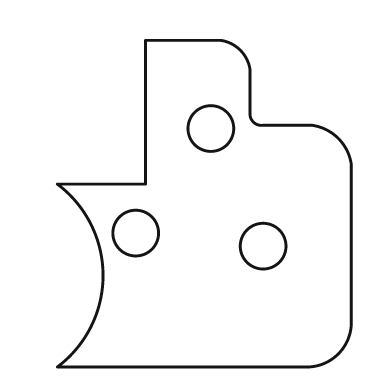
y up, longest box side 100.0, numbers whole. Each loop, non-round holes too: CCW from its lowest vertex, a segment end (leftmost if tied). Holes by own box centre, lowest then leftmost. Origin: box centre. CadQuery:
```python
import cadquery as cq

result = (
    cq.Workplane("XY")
    .moveTo(-45.0, -50.0)
    .lineTo(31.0, -50.0)
    .threePointArc((41.0, -46.0), (45.0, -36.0))
    .lineTo(45.0, 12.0)
    .threePointArc((41.0, 20.0), (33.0, 24.0))
    .lineTo(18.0, 24.0)
    .threePointArc((15.0, 25.0), (14.0, 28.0))
    .lineTo(14.0, 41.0)
    .threePointArc((11.0, 47.0), (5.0, 50.0))
    .lineTo(-18.0, 50.0)
    .lineTo(-18.0, 6.0)
    .lineTo(-45.0, 6.0)
    .threePointArc((-31.0, -22.0), (-45.0, -50.0))
    .close()
    .moveTo(18.0, -13.0)
    .circle(7.0)
    .moveTo(-21.0, -9.0)
    .circle(7.0)
    .moveTo(2.0, 23.0)
    .circle(7.0)
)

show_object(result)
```